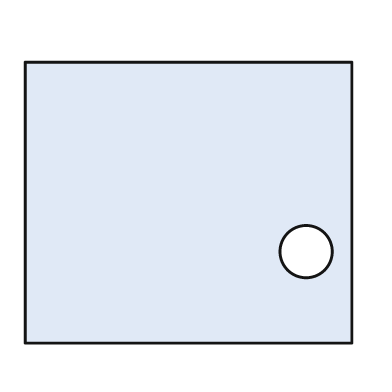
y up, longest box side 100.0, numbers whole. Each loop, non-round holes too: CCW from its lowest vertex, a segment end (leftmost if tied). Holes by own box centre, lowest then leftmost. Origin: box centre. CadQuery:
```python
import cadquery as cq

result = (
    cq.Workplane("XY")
    .moveTo(-50.0, -43.0)
    .lineTo(50.0, -43.0)
    .lineTo(50.0, 43.0)
    .lineTo(-50.0, 43.0)
    .close()
    .moveTo(36.0, -15.0)
    .circle(8.0)
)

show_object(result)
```